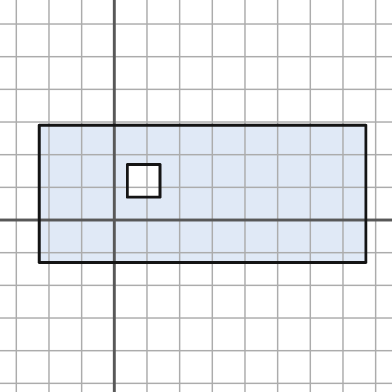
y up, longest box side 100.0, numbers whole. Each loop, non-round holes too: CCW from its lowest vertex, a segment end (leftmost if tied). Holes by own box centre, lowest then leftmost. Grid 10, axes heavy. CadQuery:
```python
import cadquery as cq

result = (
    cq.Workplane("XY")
    .moveTo(-23.0, -13.0)
    .lineTo(77.0, -13.0)
    .lineTo(77.0, 29.0)
    .lineTo(-23.0, 29.0)
    .close()
    .moveTo(4.0, 7.0)
    .lineTo(14.0, 7.0)
    .lineTo(14.0, 17.0)
    .lineTo(4.0, 17.0)
    .close()
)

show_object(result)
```